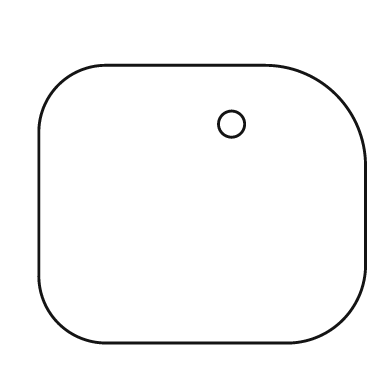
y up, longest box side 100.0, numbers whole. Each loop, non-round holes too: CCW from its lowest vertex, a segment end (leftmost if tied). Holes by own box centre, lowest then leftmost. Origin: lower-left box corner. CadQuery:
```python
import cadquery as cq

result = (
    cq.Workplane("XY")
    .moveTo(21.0, 0.0)
    .lineTo(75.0, 0.0)
    .threePointArc((93.0, 7.0), (100.0, 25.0))
    .lineTo(100.0, 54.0)
    .threePointArc((91.0, 76.0), (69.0, 85.0))
    .lineTo(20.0, 85.0)
    .threePointArc((6.0, 79.0), (0.0, 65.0))
    .lineTo(0.0, 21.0)
    .threePointArc((6.0, 6.0), (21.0, 0.0))
    .close()
    .moveTo(59.0, 67.0)
    .circle(4.0)
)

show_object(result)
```